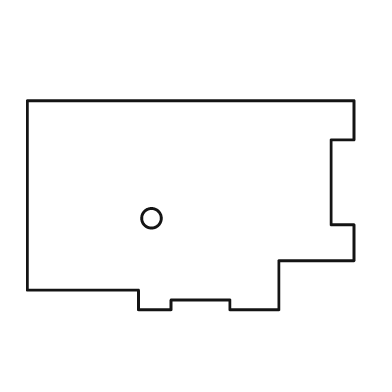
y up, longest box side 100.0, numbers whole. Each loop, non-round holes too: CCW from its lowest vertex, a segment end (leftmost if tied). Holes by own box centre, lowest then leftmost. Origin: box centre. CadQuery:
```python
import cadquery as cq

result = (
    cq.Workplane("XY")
    .moveTo(-16.0, -32.0)
    .lineTo(-6.0, -32.0)
    .lineTo(-6.0, -29.0)
    .lineTo(12.0, -29.0)
    .lineTo(12.0, -32.0)
    .lineTo(27.0, -32.0)
    .lineTo(27.0, -17.0)
    .lineTo(50.0, -17.0)
    .lineTo(50.0, -6.0)
    .lineTo(43.0, -6.0)
    .lineTo(43.0, 20.0)
    .lineTo(50.0, 20.0)
    .lineTo(50.0, 32.0)
    .lineTo(-50.0, 32.0)
    .lineTo(-50.0, -26.0)
    .lineTo(-16.0, -26.0)
    .close()
    .moveTo(-12.0, -4.0)
    .circle(3.0)
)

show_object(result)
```